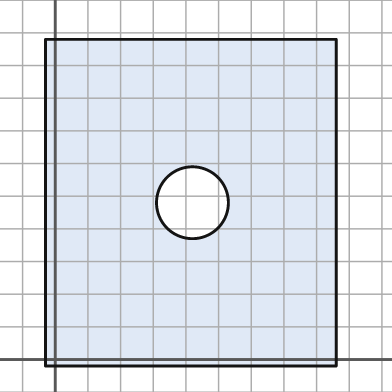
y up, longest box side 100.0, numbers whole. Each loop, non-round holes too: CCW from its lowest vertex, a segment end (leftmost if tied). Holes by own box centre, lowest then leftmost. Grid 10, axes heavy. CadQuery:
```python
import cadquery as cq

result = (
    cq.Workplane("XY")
    .moveTo(-3.0, -2.0)
    .lineTo(86.0, -2.0)
    .lineTo(86.0, 98.0)
    .lineTo(-3.0, 98.0)
    .close()
    .moveTo(42.0, 48.0)
    .circle(11.0)
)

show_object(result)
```